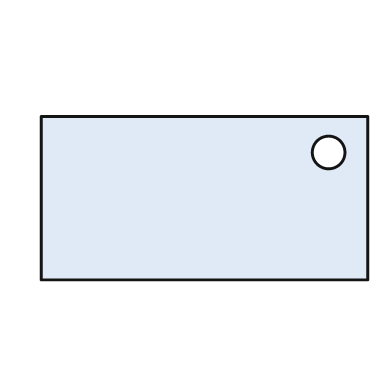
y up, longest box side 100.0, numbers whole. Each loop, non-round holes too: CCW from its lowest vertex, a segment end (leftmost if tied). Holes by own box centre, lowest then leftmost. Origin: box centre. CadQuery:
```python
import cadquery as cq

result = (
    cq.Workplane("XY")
    .moveTo(-50.0, -25.0)
    .lineTo(50.0, -25.0)
    .lineTo(50.0, 25.0)
    .lineTo(-50.0, 25.0)
    .close()
    .moveTo(38.0, 14.0)
    .circle(5.0)
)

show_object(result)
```